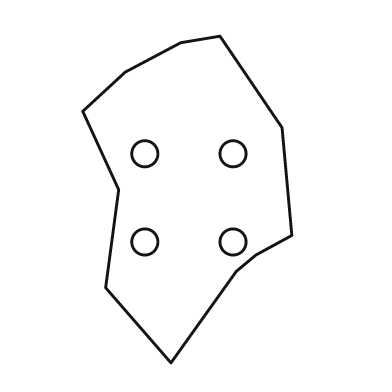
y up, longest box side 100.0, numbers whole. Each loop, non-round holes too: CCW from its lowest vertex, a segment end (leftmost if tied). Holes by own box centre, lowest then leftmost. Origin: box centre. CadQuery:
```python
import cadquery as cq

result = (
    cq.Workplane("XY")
    .moveTo(-5.0, -50.0)
    .lineTo(15.0, -22.0)
    .lineTo(21.0, -17.0)
    .lineTo(32.0, -11.0)
    .lineTo(29.0, 22.0)
    .lineTo(10.0, 50.0)
    .lineTo(-2.0, 48.0)
    .lineTo(-19.0, 39.0)
    .lineTo(-32.0, 27.0)
    .lineTo(-21.0, 3.0)
    .lineTo(-25.0, -27.0)
    .close()
    .moveTo(-13.0, -13.0)
    .circle(4.0)
    .moveTo(14.0, -13.0)
    .circle(4.0)
    .moveTo(-13.0, 14.0)
    .circle(4.0)
    .moveTo(14.0, 14.0)
    .circle(4.0)
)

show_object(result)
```